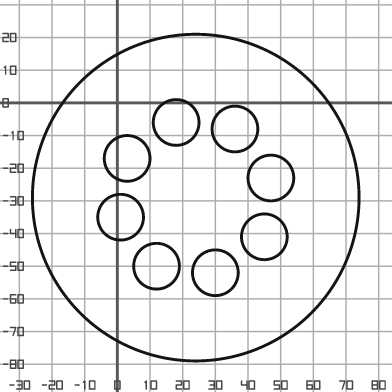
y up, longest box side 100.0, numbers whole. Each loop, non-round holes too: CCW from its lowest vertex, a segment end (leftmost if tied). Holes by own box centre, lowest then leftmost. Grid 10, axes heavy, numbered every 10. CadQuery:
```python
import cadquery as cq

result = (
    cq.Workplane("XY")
    .moveTo(24.0, -29.0)
    .circle(50.0)
    .moveTo(30.0, -52.0)
    .circle(7.0)
    .moveTo(12.0, -50.0)
    .circle(7.0)
    .moveTo(45.0, -41.0)
    .circle(7.0)
    .moveTo(1.0, -35.0)
    .circle(7.0)
    .moveTo(47.0, -23.0)
    .circle(7.0)
    .moveTo(3.0, -17.0)
    .circle(7.0)
    .moveTo(36.0, -8.0)
    .circle(7.0)
    .moveTo(18.0, -6.0)
    .circle(7.0)
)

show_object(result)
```